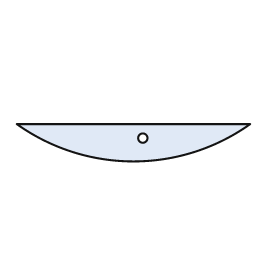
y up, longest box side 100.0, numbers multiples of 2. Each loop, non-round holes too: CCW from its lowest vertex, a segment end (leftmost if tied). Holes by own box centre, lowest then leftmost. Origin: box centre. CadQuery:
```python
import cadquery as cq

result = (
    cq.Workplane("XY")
    .moveTo(-50.0, 8.0)
    .threePointArc((0.0, -8.0), (50.0, 8.0))
    .close()
    .moveTo(4.0, 2.0)
    .circle(2.0)
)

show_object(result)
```